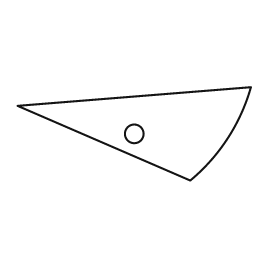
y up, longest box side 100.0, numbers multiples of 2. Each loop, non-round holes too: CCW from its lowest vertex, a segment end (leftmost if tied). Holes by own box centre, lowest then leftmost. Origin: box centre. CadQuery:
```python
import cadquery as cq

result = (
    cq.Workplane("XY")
    .moveTo(24.0, -20.0)
    .threePointArc((40.0, -2.0), (50.0, 20.0))
    .lineTo(-50.0, 12.0)
    .close()
    .moveTo(0.0, 0.0)
    .circle(4.0)
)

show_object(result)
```